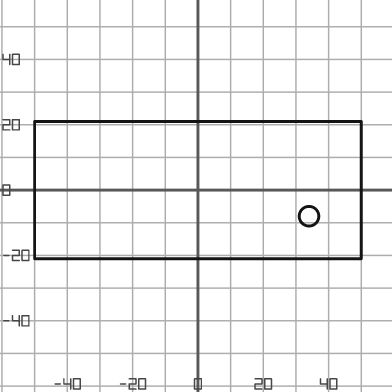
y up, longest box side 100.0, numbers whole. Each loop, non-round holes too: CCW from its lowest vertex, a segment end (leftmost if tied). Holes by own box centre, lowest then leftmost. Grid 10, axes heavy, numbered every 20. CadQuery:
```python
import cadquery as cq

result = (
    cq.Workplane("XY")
    .moveTo(-50.0, -21.0)
    .lineTo(50.0, -21.0)
    .lineTo(50.0, 21.0)
    .lineTo(-50.0, 21.0)
    .close()
    .moveTo(34.0, -8.0)
    .circle(3.0)
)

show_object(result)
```